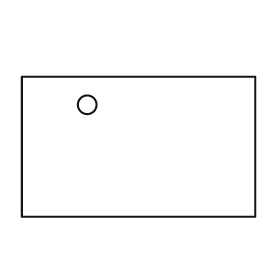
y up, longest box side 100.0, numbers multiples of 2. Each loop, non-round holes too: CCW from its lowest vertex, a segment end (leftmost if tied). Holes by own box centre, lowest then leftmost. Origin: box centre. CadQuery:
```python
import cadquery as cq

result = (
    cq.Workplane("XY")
    .moveTo(-50.0, -30.0)
    .lineTo(50.0, -30.0)
    .lineTo(50.0, 30.0)
    .lineTo(-50.0, 30.0)
    .close()
    .moveTo(-22.0, 18.0)
    .circle(4.0)
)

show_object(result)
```